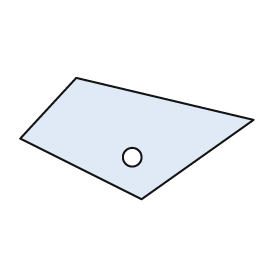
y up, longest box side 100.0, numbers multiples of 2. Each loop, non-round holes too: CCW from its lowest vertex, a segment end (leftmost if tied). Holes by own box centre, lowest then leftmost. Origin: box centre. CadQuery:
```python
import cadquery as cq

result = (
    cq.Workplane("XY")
    .moveTo(2.0, -26.0)
    .lineTo(50.0, 8.0)
    .lineTo(-26.0, 26.0)
    .lineTo(-50.0, 0.0)
    .close()
    .moveTo(-2.0, -8.0)
    .circle(4.0)
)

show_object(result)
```